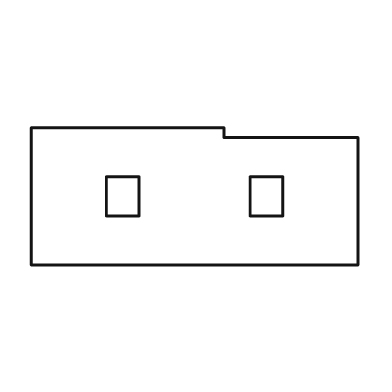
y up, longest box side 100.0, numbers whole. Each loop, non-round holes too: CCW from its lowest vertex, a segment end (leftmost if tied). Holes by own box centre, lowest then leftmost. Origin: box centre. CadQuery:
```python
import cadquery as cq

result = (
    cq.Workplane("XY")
    .moveTo(-50.0, -21.0)
    .lineTo(50.0, -21.0)
    .lineTo(50.0, 18.0)
    .lineTo(9.0, 18.0)
    .lineTo(9.0, 21.0)
    .lineTo(-50.0, 21.0)
    .close()
    .moveTo(-27.0, -6.0)
    .lineTo(-17.0, -6.0)
    .lineTo(-17.0, 6.0)
    .lineTo(-27.0, 6.0)
    .close()
    .moveTo(17.0, -6.0)
    .lineTo(27.0, -6.0)
    .lineTo(27.0, 6.0)
    .lineTo(17.0, 6.0)
    .close()
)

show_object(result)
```